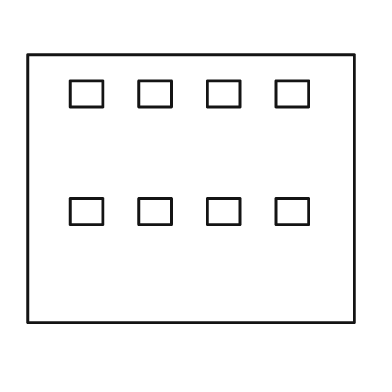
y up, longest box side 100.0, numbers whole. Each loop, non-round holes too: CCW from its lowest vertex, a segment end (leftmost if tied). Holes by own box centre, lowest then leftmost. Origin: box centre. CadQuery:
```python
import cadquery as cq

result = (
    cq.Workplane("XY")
    .moveTo(-50.0, -41.0)
    .lineTo(50.0, -41.0)
    .lineTo(50.0, 41.0)
    .lineTo(-50.0, 41.0)
    .close()
    .moveTo(-37.0, -11.0)
    .lineTo(-27.0, -11.0)
    .lineTo(-27.0, -3.0)
    .lineTo(-37.0, -3.0)
    .close()
    .moveTo(-16.0, -11.0)
    .lineTo(-6.0, -11.0)
    .lineTo(-6.0, -3.0)
    .lineTo(-16.0, -3.0)
    .close()
    .moveTo(5.0, -11.0)
    .lineTo(15.0, -11.0)
    .lineTo(15.0, -3.0)
    .lineTo(5.0, -3.0)
    .close()
    .moveTo(26.0, -11.0)
    .lineTo(36.0, -11.0)
    .lineTo(36.0, -3.0)
    .lineTo(26.0, -3.0)
    .close()
    .moveTo(-37.0, 25.0)
    .lineTo(-27.0, 25.0)
    .lineTo(-27.0, 33.0)
    .lineTo(-37.0, 33.0)
    .close()
    .moveTo(-16.0, 25.0)
    .lineTo(-6.0, 25.0)
    .lineTo(-6.0, 33.0)
    .lineTo(-16.0, 33.0)
    .close()
    .moveTo(5.0, 25.0)
    .lineTo(15.0, 25.0)
    .lineTo(15.0, 33.0)
    .lineTo(5.0, 33.0)
    .close()
    .moveTo(26.0, 25.0)
    .lineTo(36.0, 25.0)
    .lineTo(36.0, 33.0)
    .lineTo(26.0, 33.0)
    .close()
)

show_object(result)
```